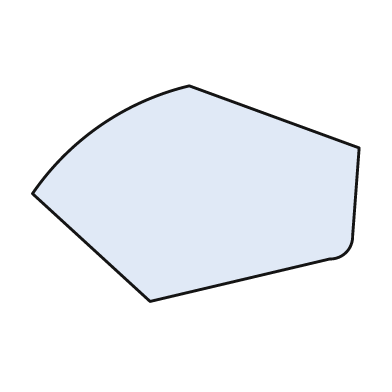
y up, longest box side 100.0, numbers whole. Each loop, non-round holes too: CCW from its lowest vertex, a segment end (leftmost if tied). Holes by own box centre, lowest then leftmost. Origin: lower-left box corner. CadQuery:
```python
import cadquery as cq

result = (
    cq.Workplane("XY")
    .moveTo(36.0, 0.0)
    .lineTo(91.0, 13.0)
    .threePointArc((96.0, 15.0), (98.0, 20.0))
    .lineTo(100.0, 47.0)
    .lineTo(48.0, 66.0)
    .threePointArc((21.0, 54.0), (0.0, 33.0))
    .close()
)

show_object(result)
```